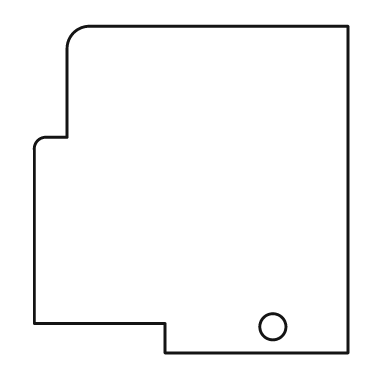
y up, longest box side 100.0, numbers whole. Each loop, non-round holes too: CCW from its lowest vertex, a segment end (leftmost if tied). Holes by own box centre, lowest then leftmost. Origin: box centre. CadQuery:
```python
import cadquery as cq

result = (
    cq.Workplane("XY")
    .moveTo(-8.0, -50.0)
    .lineTo(48.0, -50.0)
    .lineTo(48.0, 50.0)
    .lineTo(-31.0, 50.0)
    .threePointArc((-36.0, 48.0), (-38.0, 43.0))
    .lineTo(-38.0, 16.0)
    .lineTo(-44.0, 16.0)
    .threePointArc((-47.0, 15.0), (-48.0, 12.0))
    .lineTo(-48.0, -41.0)
    .lineTo(-8.0, -41.0)
    .close()
    .moveTo(25.0, -42.0)
    .circle(4.0)
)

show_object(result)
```